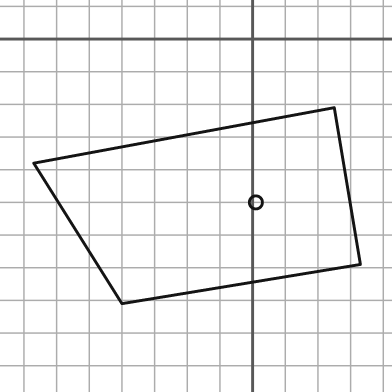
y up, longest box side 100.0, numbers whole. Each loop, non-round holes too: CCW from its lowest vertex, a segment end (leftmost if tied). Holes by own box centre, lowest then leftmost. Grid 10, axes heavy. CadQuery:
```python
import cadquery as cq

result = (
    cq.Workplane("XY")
    .moveTo(-40.0, -81.0)
    .lineTo(33.0, -69.0)
    .lineTo(25.0, -21.0)
    .lineTo(-67.0, -38.0)
    .close()
    .moveTo(1.0, -50.0)
    .circle(2.0)
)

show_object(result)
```